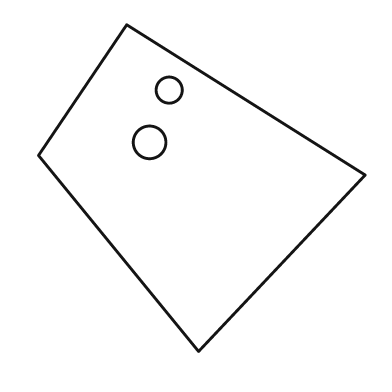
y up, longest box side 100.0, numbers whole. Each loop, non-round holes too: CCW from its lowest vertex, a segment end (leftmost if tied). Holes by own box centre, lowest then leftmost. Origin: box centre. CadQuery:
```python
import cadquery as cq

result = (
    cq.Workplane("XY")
    .moveTo(-1.0, -50.0)
    .lineTo(50.0, 4.0)
    .lineTo(-23.0, 50.0)
    .lineTo(-50.0, 10.0)
    .close()
    .moveTo(-16.0, 14.0)
    .circle(5.0)
    .moveTo(-10.0, 30.0)
    .circle(4.0)
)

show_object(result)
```